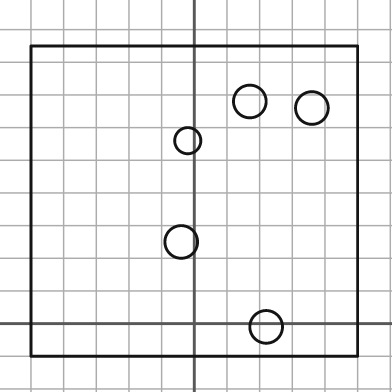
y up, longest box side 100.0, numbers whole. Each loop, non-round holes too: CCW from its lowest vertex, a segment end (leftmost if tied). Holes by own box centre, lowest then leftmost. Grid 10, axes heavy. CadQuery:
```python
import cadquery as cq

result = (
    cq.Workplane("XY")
    .moveTo(-50.0, -10.0)
    .lineTo(50.0, -10.0)
    .lineTo(50.0, 85.0)
    .lineTo(-50.0, 85.0)
    .close()
    .moveTo(22.0, -1.0)
    .circle(5.0)
    .moveTo(-4.0, 25.0)
    .circle(5.0)
    .moveTo(-2.0, 56.0)
    .circle(4.0)
    .moveTo(36.0, 66.0)
    .circle(5.0)
    .moveTo(17.0, 68.0)
    .circle(5.0)
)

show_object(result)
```